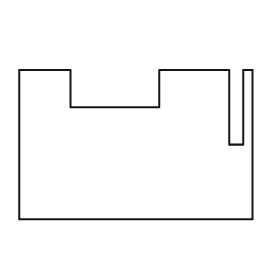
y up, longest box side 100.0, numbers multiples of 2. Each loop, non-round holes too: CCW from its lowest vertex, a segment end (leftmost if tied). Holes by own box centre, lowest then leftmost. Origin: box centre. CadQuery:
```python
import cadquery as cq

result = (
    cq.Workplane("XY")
    .moveTo(-50.0, -32.0)
    .lineTo(50.0, -32.0)
    .lineTo(50.0, 32.0)
    .lineTo(46.0, 32.0)
    .lineTo(46.0, 0.0)
    .lineTo(40.0, 0.0)
    .lineTo(40.0, 32.0)
    .lineTo(10.0, 32.0)
    .lineTo(10.0, 16.0)
    .lineTo(-28.0, 16.0)
    .lineTo(-28.0, 32.0)
    .lineTo(-50.0, 32.0)
    .close()
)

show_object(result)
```